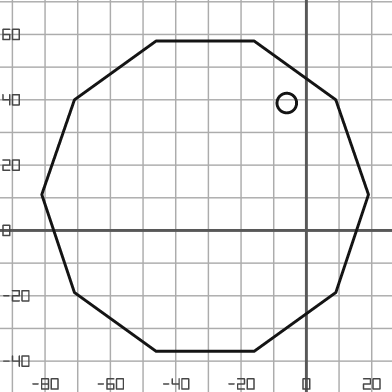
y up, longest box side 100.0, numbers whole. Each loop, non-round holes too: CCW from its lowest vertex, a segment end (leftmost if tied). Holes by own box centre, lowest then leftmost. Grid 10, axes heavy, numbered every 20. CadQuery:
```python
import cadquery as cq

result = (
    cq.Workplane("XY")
    .moveTo(-46.0, -37.0)
    .lineTo(-16.0, -37.0)
    .lineTo(9.0, -19.0)
    .lineTo(19.0, 11.0)
    .lineTo(9.0, 40.0)
    .lineTo(-16.0, 58.0)
    .lineTo(-46.0, 58.0)
    .lineTo(-71.0, 40.0)
    .lineTo(-81.0, 11.0)
    .lineTo(-71.0, -19.0)
    .close()
    .moveTo(-6.0, 39.0)
    .circle(3.0)
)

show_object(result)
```